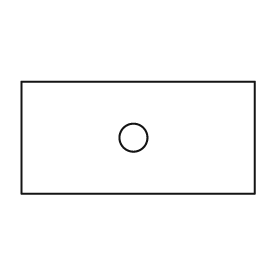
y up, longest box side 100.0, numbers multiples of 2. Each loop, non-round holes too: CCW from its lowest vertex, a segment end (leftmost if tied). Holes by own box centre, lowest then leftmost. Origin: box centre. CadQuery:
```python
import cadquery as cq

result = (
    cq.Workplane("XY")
    .moveTo(-50.0, -24.0)
    .lineTo(50.0, -24.0)
    .lineTo(50.0, 24.0)
    .lineTo(-50.0, 24.0)
    .close()
    .moveTo(-2.0, 0.0)
    .circle(6.0)
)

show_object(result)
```